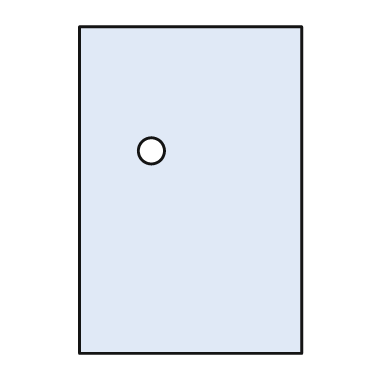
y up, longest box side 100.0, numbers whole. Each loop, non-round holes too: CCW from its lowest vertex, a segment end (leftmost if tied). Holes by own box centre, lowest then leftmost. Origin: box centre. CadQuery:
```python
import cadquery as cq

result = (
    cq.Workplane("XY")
    .moveTo(-34.0, -50.0)
    .lineTo(34.0, -50.0)
    .lineTo(34.0, 50.0)
    .lineTo(-34.0, 50.0)
    .close()
    .moveTo(-12.0, 12.0)
    .circle(4.0)
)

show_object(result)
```